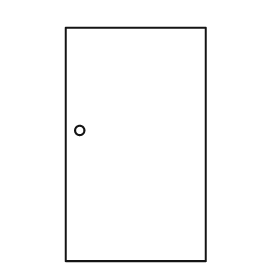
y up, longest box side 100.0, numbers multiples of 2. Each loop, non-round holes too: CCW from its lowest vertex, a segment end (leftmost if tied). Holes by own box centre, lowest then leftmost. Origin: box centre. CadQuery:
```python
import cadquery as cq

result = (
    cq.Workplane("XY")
    .moveTo(-30.0, -50.0)
    .lineTo(30.0, -50.0)
    .lineTo(30.0, 50.0)
    .lineTo(-30.0, 50.0)
    .close()
    .moveTo(-24.0, 6.0)
    .circle(2.0)
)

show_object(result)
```